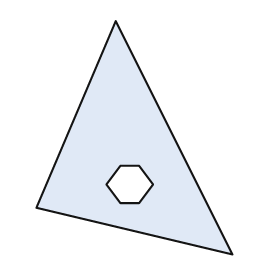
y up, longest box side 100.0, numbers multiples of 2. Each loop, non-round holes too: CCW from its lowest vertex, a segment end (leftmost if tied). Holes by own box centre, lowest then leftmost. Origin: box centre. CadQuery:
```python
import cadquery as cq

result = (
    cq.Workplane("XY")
    .moveTo(42.0, -50.0)
    .lineTo(-8.0, 50.0)
    .lineTo(-42.0, -30.0)
    .close()
    .moveTo(-6.0, -28.0)
    .lineTo(2.0, -28.0)
    .lineTo(8.0, -20.0)
    .lineTo(2.0, -12.0)
    .lineTo(-6.0, -12.0)
    .lineTo(-12.0, -20.0)
    .close()
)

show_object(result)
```